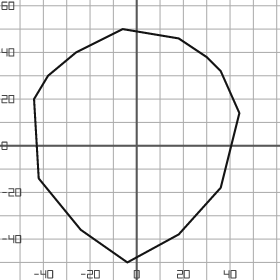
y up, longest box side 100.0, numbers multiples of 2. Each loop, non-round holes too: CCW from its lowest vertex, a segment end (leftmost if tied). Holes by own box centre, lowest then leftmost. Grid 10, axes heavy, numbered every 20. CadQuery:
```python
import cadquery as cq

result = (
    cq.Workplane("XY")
    .moveTo(-4.0, -50.0)
    .lineTo(18.0, -38.0)
    .lineTo(36.0, -18.0)
    .lineTo(44.0, 14.0)
    .lineTo(36.0, 32.0)
    .lineTo(30.0, 38.0)
    .lineTo(18.0, 46.0)
    .lineTo(-6.0, 50.0)
    .lineTo(-26.0, 40.0)
    .lineTo(-38.0, 30.0)
    .lineTo(-44.0, 20.0)
    .lineTo(-42.0, -14.0)
    .lineTo(-24.0, -36.0)
    .close()
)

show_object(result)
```